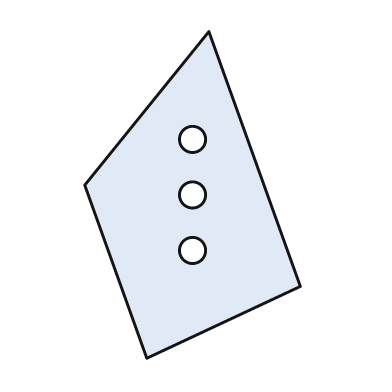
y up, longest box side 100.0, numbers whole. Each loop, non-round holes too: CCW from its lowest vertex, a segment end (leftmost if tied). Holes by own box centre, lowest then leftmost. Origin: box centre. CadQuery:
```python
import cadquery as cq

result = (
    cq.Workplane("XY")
    .moveTo(-14.0, -50.0)
    .lineTo(33.0, -28.0)
    .lineTo(5.0, 50.0)
    .lineTo(-33.0, 3.0)
    .close()
    .moveTo(0.0, -17.0)
    .circle(4.0)
    .moveTo(0.0, 0.0)
    .circle(4.0)
    .moveTo(0.0, 17.0)
    .circle(4.0)
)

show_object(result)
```